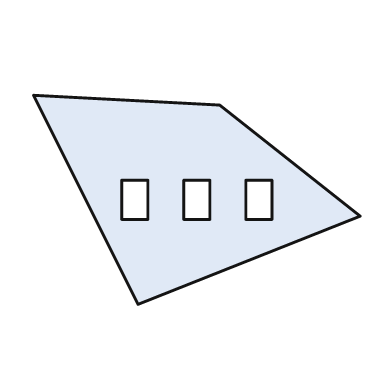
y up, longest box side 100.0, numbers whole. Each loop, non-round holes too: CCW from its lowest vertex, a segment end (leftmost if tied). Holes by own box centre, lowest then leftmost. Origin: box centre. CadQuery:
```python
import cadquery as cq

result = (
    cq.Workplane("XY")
    .moveTo(-18.0, -32.0)
    .lineTo(50.0, -5.0)
    .lineTo(7.0, 29.0)
    .lineTo(-50.0, 32.0)
    .close()
    .moveTo(-23.0, -6.0)
    .lineTo(-15.0, -6.0)
    .lineTo(-15.0, 6.0)
    .lineTo(-23.0, 6.0)
    .close()
    .moveTo(-4.0, -6.0)
    .lineTo(4.0, -6.0)
    .lineTo(4.0, 6.0)
    .lineTo(-4.0, 6.0)
    .close()
    .moveTo(15.0, -6.0)
    .lineTo(23.0, -6.0)
    .lineTo(23.0, 6.0)
    .lineTo(15.0, 6.0)
    .close()
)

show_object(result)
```